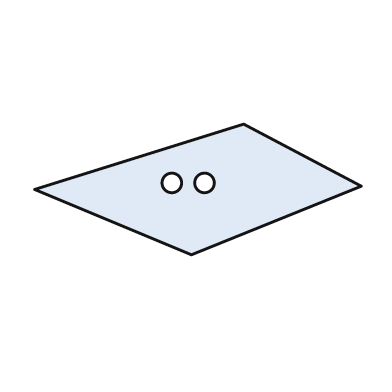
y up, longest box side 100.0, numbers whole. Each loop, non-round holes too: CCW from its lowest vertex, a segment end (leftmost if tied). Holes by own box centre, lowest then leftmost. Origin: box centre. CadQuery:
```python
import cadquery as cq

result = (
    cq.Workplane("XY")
    .moveTo(-2.0, -20.0)
    .lineTo(50.0, 1.0)
    .lineTo(14.0, 20.0)
    .lineTo(-50.0, 0.0)
    .close()
    .moveTo(-8.0, 2.0)
    .circle(3.0)
    .moveTo(2.0, 2.0)
    .circle(3.0)
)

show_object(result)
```